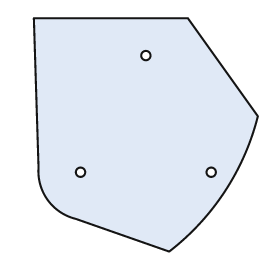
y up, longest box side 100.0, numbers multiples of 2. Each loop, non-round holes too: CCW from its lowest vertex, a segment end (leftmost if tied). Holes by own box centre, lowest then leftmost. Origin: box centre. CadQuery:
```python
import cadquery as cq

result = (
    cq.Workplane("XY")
    .moveTo(10.0, -50.0)
    .threePointArc((34.0, -24.0), (48.0, 8.0))
    .lineTo(18.0, 50.0)
    .lineTo(-48.0, 50.0)
    .lineTo(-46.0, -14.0)
    .threePointArc((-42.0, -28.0), (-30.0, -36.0))
    .close()
    .moveTo(-28.0, -16.0)
    .circle(2.0)
    .moveTo(28.0, -16.0)
    .circle(2.0)
    .moveTo(0.0, 34.0)
    .circle(2.0)
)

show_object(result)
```